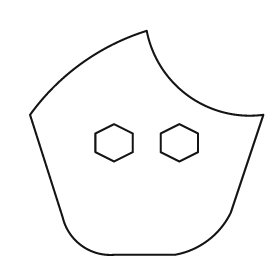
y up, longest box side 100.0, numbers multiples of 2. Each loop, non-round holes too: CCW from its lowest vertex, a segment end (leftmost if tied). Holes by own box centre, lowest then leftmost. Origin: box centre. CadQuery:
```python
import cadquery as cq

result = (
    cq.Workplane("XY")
    .moveTo(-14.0, -48.0)
    .lineTo(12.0, -48.0)
    .threePointArc((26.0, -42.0), (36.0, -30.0))
    .lineTo(50.0, 12.0)
    .threePointArc((18.0, 20.0), (0.0, 48.0))
    .threePointArc((-28.0, 34.0), (-50.0, 12.0))
    .lineTo(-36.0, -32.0)
    .threePointArc((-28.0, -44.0), (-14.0, -48.0))
    .close()
    .moveTo(-14.0, -8.0)
    .lineTo(-6.0, -4.0)
    .lineTo(-6.0, 4.0)
    .lineTo(-14.0, 8.0)
    .lineTo(-22.0, 4.0)
    .lineTo(-22.0, -4.0)
    .close()
    .moveTo(14.0, -8.0)
    .lineTo(22.0, -4.0)
    .lineTo(22.0, 4.0)
    .lineTo(14.0, 8.0)
    .lineTo(6.0, 4.0)
    .lineTo(6.0, -4.0)
    .close()
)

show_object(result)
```